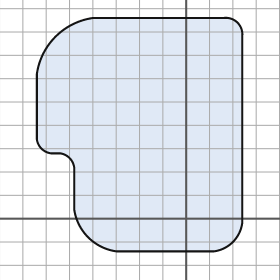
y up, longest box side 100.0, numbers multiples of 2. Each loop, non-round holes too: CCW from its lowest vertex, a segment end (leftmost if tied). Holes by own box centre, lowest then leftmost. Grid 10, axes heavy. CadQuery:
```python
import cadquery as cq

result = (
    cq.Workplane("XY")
    .moveTo(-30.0, -14.0)
    .lineTo(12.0, -14.0)
    .threePointArc((20.0, -10.0), (24.0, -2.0))
    .lineTo(24.0, 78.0)
    .threePointArc((22.0, 84.0), (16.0, 86.0))
    .lineTo(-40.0, 86.0)
    .threePointArc((-56.0, 78.0), (-64.0, 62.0))
    .lineTo(-64.0, 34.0)
    .threePointArc((-62.0, 30.0), (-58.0, 28.0))
    .lineTo(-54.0, 28.0)
    .threePointArc((-50.0, 26.0), (-48.0, 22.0))
    .lineTo(-48.0, 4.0)
    .threePointArc((-42.0, -8.0), (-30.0, -14.0))
    .close()
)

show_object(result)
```